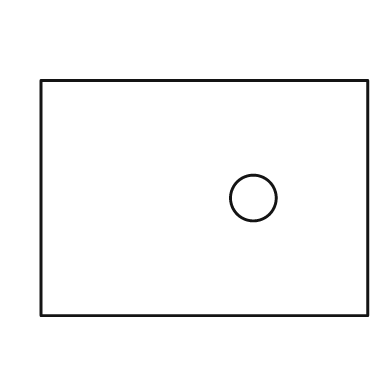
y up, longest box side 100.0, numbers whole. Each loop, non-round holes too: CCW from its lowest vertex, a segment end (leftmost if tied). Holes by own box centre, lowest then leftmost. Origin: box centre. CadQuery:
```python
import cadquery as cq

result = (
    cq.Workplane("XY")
    .moveTo(-50.0, -36.0)
    .lineTo(50.0, -36.0)
    .lineTo(50.0, 36.0)
    .lineTo(-50.0, 36.0)
    .close()
    .moveTo(15.0, 0.0)
    .circle(7.0)
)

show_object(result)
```